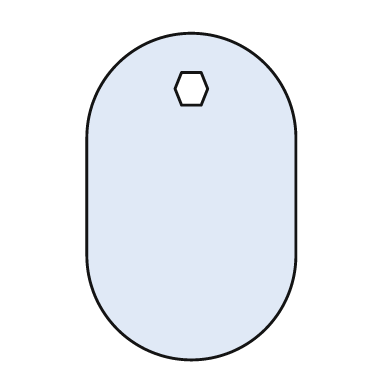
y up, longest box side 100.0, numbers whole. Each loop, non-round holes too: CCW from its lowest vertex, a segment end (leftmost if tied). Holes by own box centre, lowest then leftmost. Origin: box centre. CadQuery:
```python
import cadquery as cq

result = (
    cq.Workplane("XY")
    .moveTo(-32.0, -18.0)
    .threePointArc((0.0, -50.0), (32.0, -18.0))
    .lineTo(32.0, 18.0)
    .threePointArc((0.0, 50.0), (-32.0, 18.0))
    .close()
    .moveTo(-3.0, 28.0)
    .lineTo(3.0, 28.0)
    .lineTo(5.0, 33.0)
    .lineTo(3.0, 38.0)
    .lineTo(-3.0, 38.0)
    .lineTo(-5.0, 33.0)
    .close()
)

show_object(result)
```